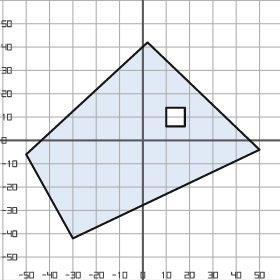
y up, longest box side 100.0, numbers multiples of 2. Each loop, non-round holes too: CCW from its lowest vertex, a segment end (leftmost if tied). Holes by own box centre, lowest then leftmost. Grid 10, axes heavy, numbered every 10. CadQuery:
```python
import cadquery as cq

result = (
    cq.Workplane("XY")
    .moveTo(-30.0, -42.0)
    .lineTo(50.0, -4.0)
    .lineTo(2.0, 42.0)
    .lineTo(-50.0, -6.0)
    .close()
    .moveTo(10.0, 6.0)
    .lineTo(18.0, 6.0)
    .lineTo(18.0, 14.0)
    .lineTo(10.0, 14.0)
    .close()
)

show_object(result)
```